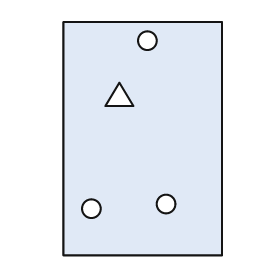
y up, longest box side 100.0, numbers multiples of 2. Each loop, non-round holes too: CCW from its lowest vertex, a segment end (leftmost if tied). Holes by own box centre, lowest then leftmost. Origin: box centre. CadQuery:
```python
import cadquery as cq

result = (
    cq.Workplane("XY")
    .moveTo(-34.0, -50.0)
    .lineTo(34.0, -50.0)
    .lineTo(34.0, 50.0)
    .lineTo(-34.0, 50.0)
    .close()
    .moveTo(-22.0, -30.0)
    .circle(4.0)
    .moveTo(10.0, -28.0)
    .circle(4.0)
    .moveTo(-16.0, 14.0)
    .lineTo(-4.0, 14.0)
    .lineTo(-10.0, 24.0)
    .close()
    .moveTo(2.0, 42.0)
    .circle(4.0)
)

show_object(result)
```